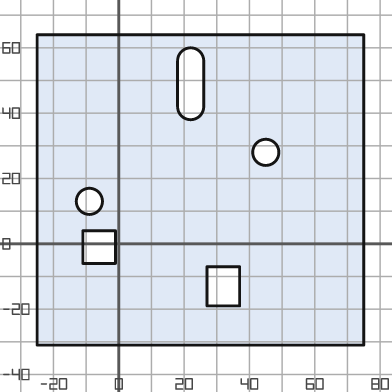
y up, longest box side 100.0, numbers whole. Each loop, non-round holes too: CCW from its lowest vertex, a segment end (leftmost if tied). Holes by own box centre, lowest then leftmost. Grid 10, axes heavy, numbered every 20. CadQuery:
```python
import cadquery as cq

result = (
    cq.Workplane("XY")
    .moveTo(-25.0, -31.0)
    .lineTo(75.0, -31.0)
    .lineTo(75.0, 64.0)
    .lineTo(-25.0, 64.0)
    .close()
    .moveTo(27.0, -19.0)
    .lineTo(37.0, -19.0)
    .lineTo(37.0, -7.0)
    .lineTo(27.0, -7.0)
    .close()
    .moveTo(-11.0, -6.0)
    .lineTo(-1.0, -6.0)
    .lineTo(-1.0, 4.0)
    .lineTo(-11.0, 4.0)
    .close()
    .moveTo(-9.0, 13.0)
    .circle(4.0)
    .moveTo(45.0, 28.0)
    .circle(4.0)
    .moveTo(18.0, 42.0)
    .threePointArc((22.0, 38.0), (26.0, 42.0))
    .lineTo(26.0, 56.0)
    .threePointArc((22.0, 60.0), (18.0, 56.0))
    .close()
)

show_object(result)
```